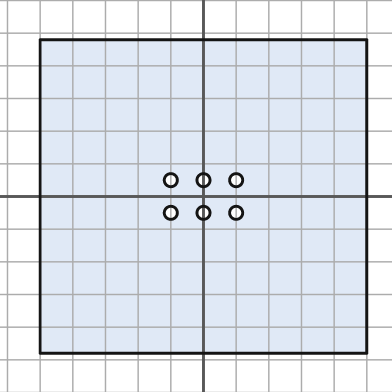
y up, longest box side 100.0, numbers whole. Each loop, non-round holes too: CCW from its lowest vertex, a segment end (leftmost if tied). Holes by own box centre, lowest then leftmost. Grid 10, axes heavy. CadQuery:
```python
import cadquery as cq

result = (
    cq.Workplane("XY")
    .moveTo(-50.0, -48.0)
    .lineTo(50.0, -48.0)
    .lineTo(50.0, 48.0)
    .lineTo(-50.0, 48.0)
    .close()
    .moveTo(-10.0, -5.0)
    .circle(2.0)
    .moveTo(0.0, -5.0)
    .circle(2.0)
    .moveTo(10.0, -5.0)
    .circle(2.0)
    .moveTo(-10.0, 5.0)
    .circle(2.0)
    .moveTo(0.0, 5.0)
    .circle(2.0)
    .moveTo(10.0, 5.0)
    .circle(2.0)
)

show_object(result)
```